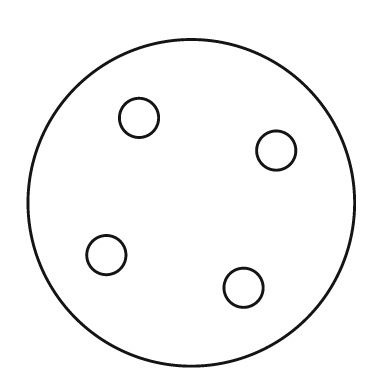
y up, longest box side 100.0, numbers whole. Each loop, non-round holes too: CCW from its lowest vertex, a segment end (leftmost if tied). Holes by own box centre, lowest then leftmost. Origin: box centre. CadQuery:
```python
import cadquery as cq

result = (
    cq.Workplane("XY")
    .moveTo(0.0, 0.0)
    .circle(50.0)
    .moveTo(16.0, -26.0)
    .circle(6.0)
    .moveTo(-26.0, -16.0)
    .circle(6.0)
    .moveTo(26.0, 16.0)
    .circle(6.0)
    .moveTo(-16.0, 26.0)
    .circle(6.0)
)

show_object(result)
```